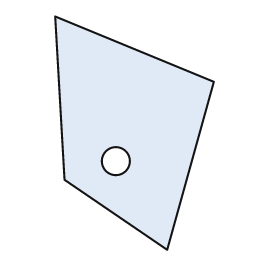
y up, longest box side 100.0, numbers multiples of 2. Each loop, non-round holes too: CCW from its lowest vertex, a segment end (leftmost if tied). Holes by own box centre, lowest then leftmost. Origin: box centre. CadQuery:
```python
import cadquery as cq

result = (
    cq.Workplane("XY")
    .moveTo(14.0, -50.0)
    .lineTo(34.0, 22.0)
    .lineTo(-34.0, 50.0)
    .lineTo(-30.0, -20.0)
    .close()
    .moveTo(-8.0, -12.0)
    .circle(6.0)
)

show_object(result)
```